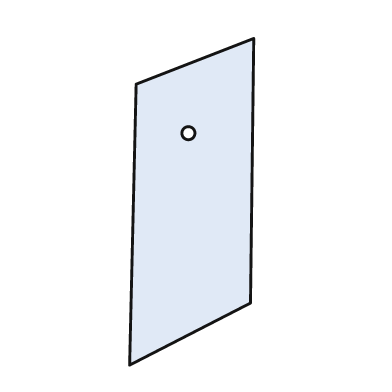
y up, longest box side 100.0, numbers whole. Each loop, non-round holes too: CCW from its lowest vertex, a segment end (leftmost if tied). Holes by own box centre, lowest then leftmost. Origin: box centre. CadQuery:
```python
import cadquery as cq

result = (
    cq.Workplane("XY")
    .moveTo(-19.0, -50.0)
    .lineTo(18.0, -31.0)
    .lineTo(19.0, 50.0)
    .lineTo(-17.0, 36.0)
    .close()
    .moveTo(-1.0, 21.0)
    .circle(2.0)
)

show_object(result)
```